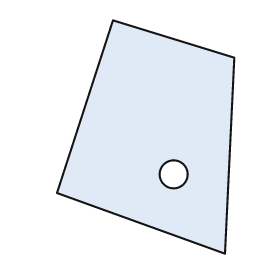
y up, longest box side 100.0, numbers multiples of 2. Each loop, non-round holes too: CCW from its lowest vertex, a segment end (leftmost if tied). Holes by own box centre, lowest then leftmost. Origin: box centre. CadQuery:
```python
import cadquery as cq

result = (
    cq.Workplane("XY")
    .moveTo(34.0, -50.0)
    .lineTo(38.0, 34.0)
    .lineTo(-14.0, 50.0)
    .lineTo(-38.0, -24.0)
    .close()
    .moveTo(12.0, -16.0)
    .circle(6.0)
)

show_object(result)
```